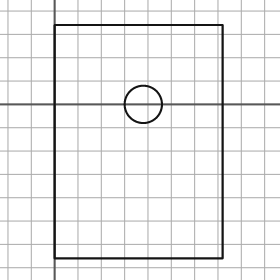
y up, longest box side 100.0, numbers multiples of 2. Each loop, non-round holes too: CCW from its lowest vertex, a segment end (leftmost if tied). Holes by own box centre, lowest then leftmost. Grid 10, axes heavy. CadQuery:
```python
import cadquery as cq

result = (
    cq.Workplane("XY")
    .moveTo(0.0, -66.0)
    .lineTo(72.0, -66.0)
    .lineTo(72.0, 34.0)
    .lineTo(0.0, 34.0)
    .close()
    .moveTo(38.0, 0.0)
    .circle(8.0)
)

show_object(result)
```